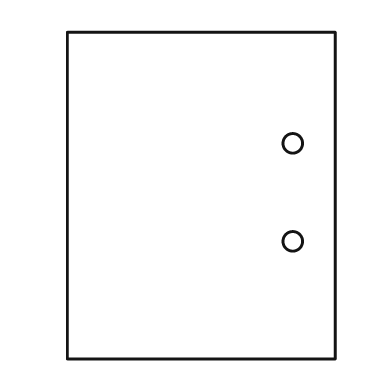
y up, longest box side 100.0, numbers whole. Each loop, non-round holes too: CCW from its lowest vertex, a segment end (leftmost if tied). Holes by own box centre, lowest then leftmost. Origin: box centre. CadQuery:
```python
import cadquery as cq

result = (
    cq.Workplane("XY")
    .moveTo(-41.0, -50.0)
    .lineTo(41.0, -50.0)
    .lineTo(41.0, 50.0)
    .lineTo(-41.0, 50.0)
    .close()
    .moveTo(28.0, -14.0)
    .circle(3.0)
    .moveTo(28.0, 16.0)
    .circle(3.0)
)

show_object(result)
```